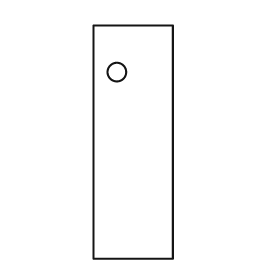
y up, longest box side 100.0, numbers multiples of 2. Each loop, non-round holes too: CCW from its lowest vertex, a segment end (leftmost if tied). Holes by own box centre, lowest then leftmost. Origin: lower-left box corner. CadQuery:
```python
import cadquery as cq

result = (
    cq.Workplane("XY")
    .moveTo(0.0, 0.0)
    .lineTo(34.0, 0.0)
    .lineTo(34.0, 100.0)
    .lineTo(0.0, 100.0)
    .close()
    .moveTo(10.0, 80.0)
    .circle(4.0)
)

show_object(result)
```